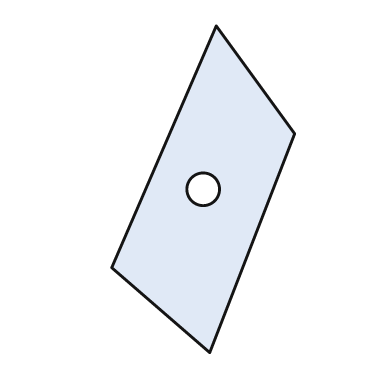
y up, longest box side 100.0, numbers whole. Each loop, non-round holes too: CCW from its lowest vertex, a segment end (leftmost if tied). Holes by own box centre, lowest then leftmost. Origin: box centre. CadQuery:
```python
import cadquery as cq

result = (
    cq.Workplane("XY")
    .moveTo(2.0, -50.0)
    .lineTo(28.0, 17.0)
    .lineTo(4.0, 50.0)
    .lineTo(-28.0, -24.0)
    .close()
    .moveTo(0.0, 0.0)
    .circle(5.0)
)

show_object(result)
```